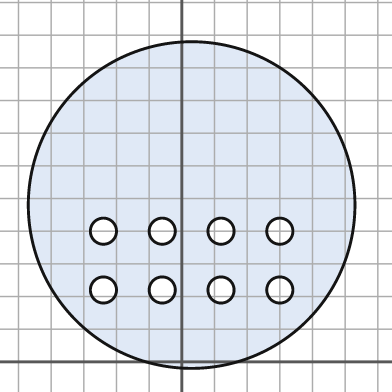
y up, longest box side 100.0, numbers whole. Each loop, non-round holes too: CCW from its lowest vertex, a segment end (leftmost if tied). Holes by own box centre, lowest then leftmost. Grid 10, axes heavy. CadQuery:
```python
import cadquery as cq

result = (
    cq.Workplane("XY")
    .moveTo(3.0, 48.0)
    .circle(50.0)
    .moveTo(-24.0, 22.0)
    .circle(4.0)
    .moveTo(-6.0, 22.0)
    .circle(4.0)
    .moveTo(12.0, 22.0)
    .circle(4.0)
    .moveTo(30.0, 22.0)
    .circle(4.0)
    .moveTo(-24.0, 40.0)
    .circle(4.0)
    .moveTo(-6.0, 40.0)
    .circle(4.0)
    .moveTo(12.0, 40.0)
    .circle(4.0)
    .moveTo(30.0, 40.0)
    .circle(4.0)
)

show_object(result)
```